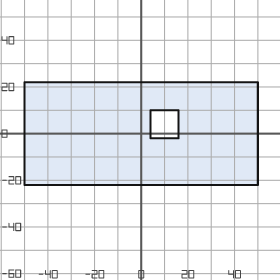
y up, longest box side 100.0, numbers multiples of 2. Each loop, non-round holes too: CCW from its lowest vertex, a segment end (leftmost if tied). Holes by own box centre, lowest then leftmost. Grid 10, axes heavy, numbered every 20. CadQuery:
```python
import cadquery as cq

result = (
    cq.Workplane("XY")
    .moveTo(-50.0, -22.0)
    .lineTo(50.0, -22.0)
    .lineTo(50.0, 22.0)
    .lineTo(-50.0, 22.0)
    .close()
    .moveTo(4.0, -2.0)
    .lineTo(16.0, -2.0)
    .lineTo(16.0, 10.0)
    .lineTo(4.0, 10.0)
    .close()
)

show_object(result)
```